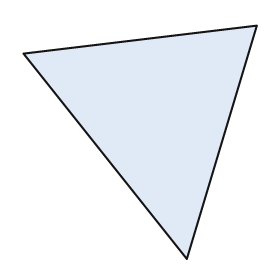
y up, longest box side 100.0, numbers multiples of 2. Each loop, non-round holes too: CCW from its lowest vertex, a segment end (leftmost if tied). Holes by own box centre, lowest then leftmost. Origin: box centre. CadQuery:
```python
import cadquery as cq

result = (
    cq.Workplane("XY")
    .moveTo(20.0, -50.0)
    .lineTo(50.0, 50.0)
    .lineTo(-50.0, 38.0)
    .close()
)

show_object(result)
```